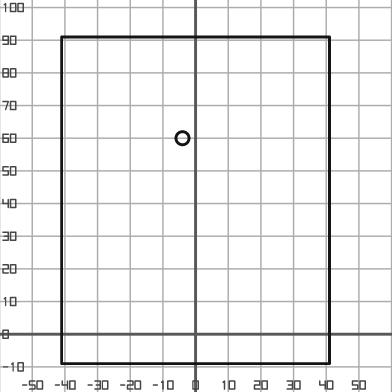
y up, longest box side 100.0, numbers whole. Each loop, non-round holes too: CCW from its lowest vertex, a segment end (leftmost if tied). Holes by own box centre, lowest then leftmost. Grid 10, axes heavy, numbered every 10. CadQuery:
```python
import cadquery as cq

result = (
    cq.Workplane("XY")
    .moveTo(-41.0, -9.0)
    .lineTo(41.0, -9.0)
    .lineTo(41.0, 91.0)
    .lineTo(-41.0, 91.0)
    .close()
    .moveTo(-4.0, 60.0)
    .circle(2.0)
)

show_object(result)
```